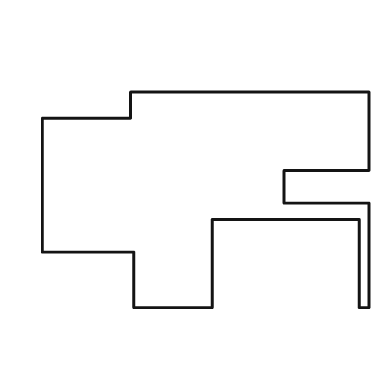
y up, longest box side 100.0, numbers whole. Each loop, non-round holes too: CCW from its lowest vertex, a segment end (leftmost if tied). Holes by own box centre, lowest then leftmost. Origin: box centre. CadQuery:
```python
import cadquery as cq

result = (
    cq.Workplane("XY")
    .moveTo(-22.0, -33.0)
    .lineTo(2.0, -33.0)
    .lineTo(2.0, -6.0)
    .lineTo(47.0, -6.0)
    .lineTo(47.0, -33.0)
    .lineTo(50.0, -33.0)
    .lineTo(50.0, -1.0)
    .lineTo(24.0, -1.0)
    .lineTo(24.0, 9.0)
    .lineTo(50.0, 9.0)
    .lineTo(50.0, 33.0)
    .lineTo(-23.0, 33.0)
    .lineTo(-23.0, 25.0)
    .lineTo(-50.0, 25.0)
    .lineTo(-50.0, -16.0)
    .lineTo(-22.0, -16.0)
    .close()
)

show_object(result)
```